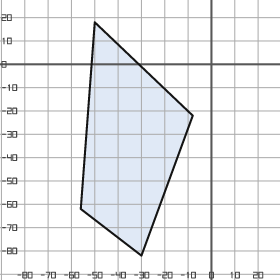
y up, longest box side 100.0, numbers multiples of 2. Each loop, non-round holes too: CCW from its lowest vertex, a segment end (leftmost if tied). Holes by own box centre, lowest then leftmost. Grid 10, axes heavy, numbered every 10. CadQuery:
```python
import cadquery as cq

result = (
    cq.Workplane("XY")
    .moveTo(-30.0, -82.0)
    .lineTo(-8.0, -22.0)
    .lineTo(-50.0, 18.0)
    .lineTo(-56.0, -62.0)
    .close()
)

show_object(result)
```